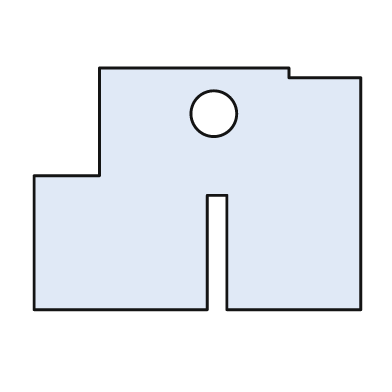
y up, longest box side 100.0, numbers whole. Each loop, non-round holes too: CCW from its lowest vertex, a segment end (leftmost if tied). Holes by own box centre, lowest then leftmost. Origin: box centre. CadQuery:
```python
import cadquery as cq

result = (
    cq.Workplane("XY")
    .moveTo(-50.0, -37.0)
    .lineTo(3.0, -37.0)
    .lineTo(3.0, -2.0)
    .lineTo(9.0, -2.0)
    .lineTo(9.0, -37.0)
    .lineTo(50.0, -37.0)
    .lineTo(50.0, 34.0)
    .lineTo(28.0, 34.0)
    .lineTo(28.0, 37.0)
    .lineTo(-30.0, 37.0)
    .lineTo(-30.0, 4.0)
    .lineTo(-50.0, 4.0)
    .close()
    .moveTo(5.0, 23.0)
    .circle(7.0)
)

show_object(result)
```